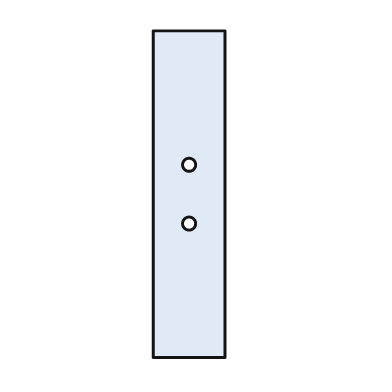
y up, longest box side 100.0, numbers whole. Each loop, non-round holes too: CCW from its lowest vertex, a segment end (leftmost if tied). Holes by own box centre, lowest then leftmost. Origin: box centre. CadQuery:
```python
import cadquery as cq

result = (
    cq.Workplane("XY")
    .moveTo(-11.0, -50.0)
    .lineTo(11.0, -50.0)
    .lineTo(11.0, 50.0)
    .lineTo(-11.0, 50.0)
    .close()
    .moveTo(0.0, -9.0)
    .circle(2.0)
    .moveTo(0.0, 9.0)
    .circle(2.0)
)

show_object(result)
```